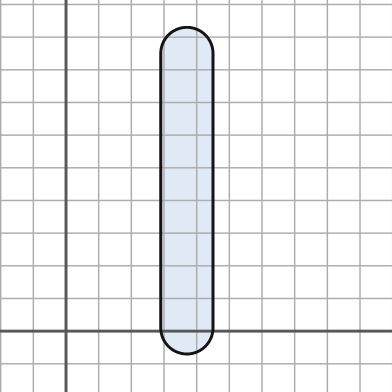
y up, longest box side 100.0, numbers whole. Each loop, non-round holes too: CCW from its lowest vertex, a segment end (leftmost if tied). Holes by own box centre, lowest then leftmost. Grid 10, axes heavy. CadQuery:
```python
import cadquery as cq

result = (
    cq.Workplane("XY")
    .moveTo(29.0, 1.0)
    .threePointArc((37.0, -7.0), (45.0, 1.0))
    .lineTo(45.0, 85.0)
    .threePointArc((37.0, 93.0), (29.0, 85.0))
    .close()
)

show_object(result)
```